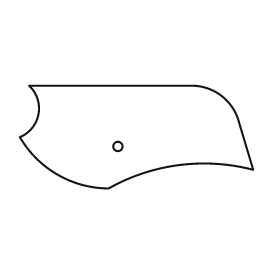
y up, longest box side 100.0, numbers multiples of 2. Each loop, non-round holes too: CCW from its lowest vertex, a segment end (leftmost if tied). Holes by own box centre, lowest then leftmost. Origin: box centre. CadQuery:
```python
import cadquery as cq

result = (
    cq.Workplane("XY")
    .moveTo(-12.0, -22.0)
    .threePointArc((18.0, -12.0), (50.0, -14.0))
    .lineTo(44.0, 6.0)
    .threePointArc((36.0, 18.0), (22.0, 22.0))
    .lineTo(-46.0, 22.0)
    .threePointArc((-42.0, 10.0), (-50.0, 0.0))
    .threePointArc((-34.0, -16.0), (-12.0, -22.0))
    .close()
    .moveTo(-8.0, -4.0)
    .circle(2.0)
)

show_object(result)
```